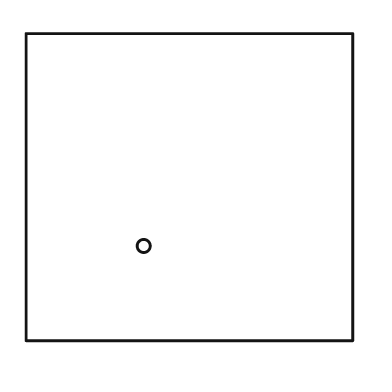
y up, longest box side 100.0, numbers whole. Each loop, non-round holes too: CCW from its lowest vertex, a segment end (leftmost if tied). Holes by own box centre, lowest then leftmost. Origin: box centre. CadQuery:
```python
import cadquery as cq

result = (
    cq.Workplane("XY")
    .moveTo(-50.0, -47.0)
    .lineTo(50.0, -47.0)
    .lineTo(50.0, 47.0)
    .lineTo(-50.0, 47.0)
    .close()
    .moveTo(-14.0, -18.0)
    .circle(2.0)
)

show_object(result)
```